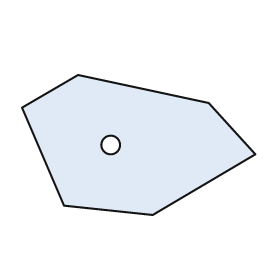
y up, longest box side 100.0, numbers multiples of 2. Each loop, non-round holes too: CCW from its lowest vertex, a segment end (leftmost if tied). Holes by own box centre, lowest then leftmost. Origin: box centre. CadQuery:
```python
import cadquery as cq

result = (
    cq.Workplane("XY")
    .moveTo(6.0, -30.0)
    .lineTo(50.0, -4.0)
    .lineTo(30.0, 18.0)
    .lineTo(-26.0, 30.0)
    .lineTo(-50.0, 16.0)
    .lineTo(-32.0, -26.0)
    .close()
    .moveTo(-12.0, 0.0)
    .circle(4.0)
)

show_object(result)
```